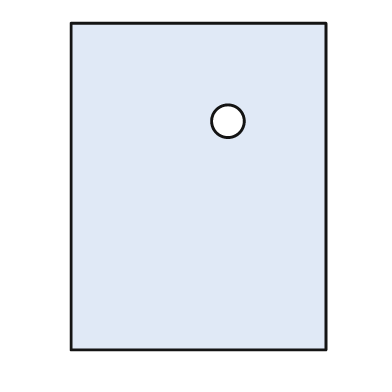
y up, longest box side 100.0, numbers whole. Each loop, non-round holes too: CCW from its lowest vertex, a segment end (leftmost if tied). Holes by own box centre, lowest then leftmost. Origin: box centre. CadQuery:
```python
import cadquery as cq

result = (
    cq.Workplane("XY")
    .moveTo(-39.0, -50.0)
    .lineTo(39.0, -50.0)
    .lineTo(39.0, 50.0)
    .lineTo(-39.0, 50.0)
    .close()
    .moveTo(9.0, 20.0)
    .circle(5.0)
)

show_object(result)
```